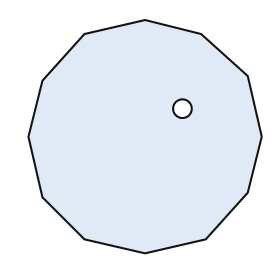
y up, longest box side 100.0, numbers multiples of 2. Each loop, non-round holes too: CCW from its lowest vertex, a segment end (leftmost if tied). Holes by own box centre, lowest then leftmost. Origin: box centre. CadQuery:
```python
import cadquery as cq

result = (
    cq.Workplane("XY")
    .moveTo(0.0, -50.0)
    .lineTo(26.0, -44.0)
    .lineTo(44.0, -24.0)
    .lineTo(50.0, 0.0)
    .lineTo(44.0, 26.0)
    .lineTo(24.0, 44.0)
    .lineTo(0.0, 50.0)
    .lineTo(-26.0, 44.0)
    .lineTo(-44.0, 24.0)
    .lineTo(-50.0, 0.0)
    .lineTo(-44.0, -26.0)
    .lineTo(-26.0, -44.0)
    .close()
    .moveTo(16.0, 12.0)
    .circle(4.0)
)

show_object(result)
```